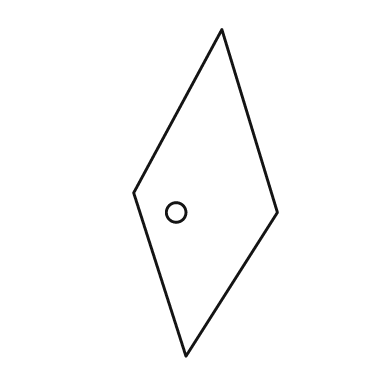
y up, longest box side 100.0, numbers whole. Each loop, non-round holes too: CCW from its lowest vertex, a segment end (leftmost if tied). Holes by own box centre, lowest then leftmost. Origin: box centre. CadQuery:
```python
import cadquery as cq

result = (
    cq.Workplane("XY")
    .moveTo(-6.0, -50.0)
    .lineTo(22.0, -6.0)
    .lineTo(5.0, 50.0)
    .lineTo(-22.0, 0.0)
    .close()
    .moveTo(-9.0, -6.0)
    .circle(3.0)
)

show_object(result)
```